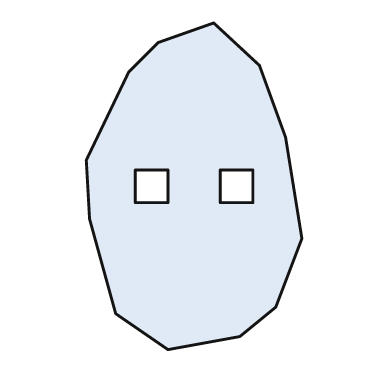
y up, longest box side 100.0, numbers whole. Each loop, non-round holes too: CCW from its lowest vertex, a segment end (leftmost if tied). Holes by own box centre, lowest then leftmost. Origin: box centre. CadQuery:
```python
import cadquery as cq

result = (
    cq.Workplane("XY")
    .moveTo(-8.0, -50.0)
    .lineTo(14.0, -46.0)
    .lineTo(25.0, -37.0)
    .lineTo(33.0, -16.0)
    .lineTo(28.0, 15.0)
    .lineTo(20.0, 37.0)
    .lineTo(6.0, 50.0)
    .lineTo(-11.0, 44.0)
    .lineTo(-20.0, 35.0)
    .lineTo(-33.0, 8.0)
    .lineTo(-32.0, -10.0)
    .lineTo(-24.0, -39.0)
    .close()
    .moveTo(-18.0, -5.0)
    .lineTo(-8.0, -5.0)
    .lineTo(-8.0, 5.0)
    .lineTo(-18.0, 5.0)
    .close()
    .moveTo(8.0, -5.0)
    .lineTo(18.0, -5.0)
    .lineTo(18.0, 5.0)
    .lineTo(8.0, 5.0)
    .close()
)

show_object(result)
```